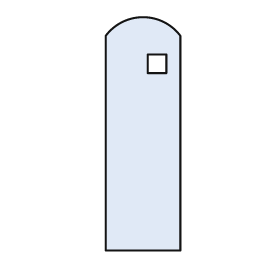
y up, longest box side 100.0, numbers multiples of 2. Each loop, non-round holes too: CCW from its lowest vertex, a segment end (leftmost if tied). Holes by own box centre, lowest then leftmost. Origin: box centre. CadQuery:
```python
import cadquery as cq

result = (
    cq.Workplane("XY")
    .moveTo(-16.0, -50.0)
    .lineTo(16.0, -50.0)
    .lineTo(16.0, 42.0)
    .threePointArc((0.0, 50.0), (-16.0, 42.0))
    .close()
    .moveTo(2.0, 26.0)
    .lineTo(10.0, 26.0)
    .lineTo(10.0, 34.0)
    .lineTo(2.0, 34.0)
    .close()
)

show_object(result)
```